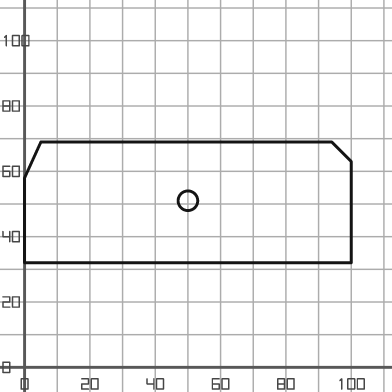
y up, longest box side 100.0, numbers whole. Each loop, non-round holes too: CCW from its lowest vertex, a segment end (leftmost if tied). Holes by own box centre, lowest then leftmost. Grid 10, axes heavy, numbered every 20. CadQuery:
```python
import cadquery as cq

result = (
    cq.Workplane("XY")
    .moveTo(0.0, 32.0)
    .lineTo(100.0, 32.0)
    .lineTo(100.0, 63.0)
    .lineTo(94.0, 69.0)
    .lineTo(5.0, 69.0)
    .lineTo(0.0, 58.0)
    .close()
    .moveTo(50.0, 51.0)
    .circle(3.0)
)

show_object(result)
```